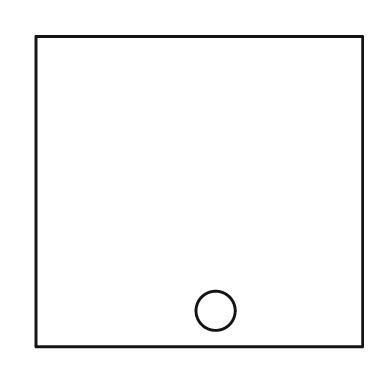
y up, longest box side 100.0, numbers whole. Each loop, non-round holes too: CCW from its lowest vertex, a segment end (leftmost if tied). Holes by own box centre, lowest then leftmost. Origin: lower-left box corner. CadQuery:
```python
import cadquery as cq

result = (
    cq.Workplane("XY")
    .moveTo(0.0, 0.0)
    .lineTo(100.0, 0.0)
    .lineTo(100.0, 95.0)
    .lineTo(0.0, 95.0)
    .close()
    .moveTo(55.0, 11.0)
    .circle(6.0)
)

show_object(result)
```